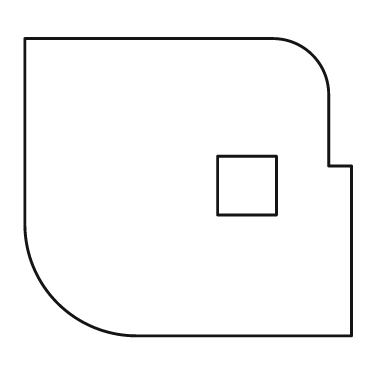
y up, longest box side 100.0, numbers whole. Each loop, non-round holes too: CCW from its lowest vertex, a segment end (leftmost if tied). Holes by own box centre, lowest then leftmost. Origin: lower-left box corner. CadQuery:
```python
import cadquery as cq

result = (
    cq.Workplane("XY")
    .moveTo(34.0, 0.0)
    .lineTo(100.0, 0.0)
    .lineTo(100.0, 52.0)
    .lineTo(93.0, 52.0)
    .lineTo(93.0, 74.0)
    .threePointArc((88.0, 86.0), (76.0, 91.0))
    .lineTo(0.0, 91.0)
    .lineTo(0.0, 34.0)
    .threePointArc((10.0, 10.0), (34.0, 0.0))
    .close()
    .moveTo(59.0, 37.0)
    .lineTo(77.0, 37.0)
    .lineTo(77.0, 55.0)
    .lineTo(59.0, 55.0)
    .close()
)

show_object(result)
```